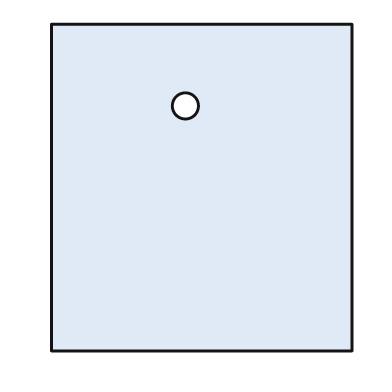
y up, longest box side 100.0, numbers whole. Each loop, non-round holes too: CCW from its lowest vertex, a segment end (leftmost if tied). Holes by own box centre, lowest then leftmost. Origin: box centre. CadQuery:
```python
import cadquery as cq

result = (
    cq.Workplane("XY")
    .moveTo(-46.0, -50.0)
    .lineTo(46.0, -50.0)
    .lineTo(46.0, 50.0)
    .lineTo(-46.0, 50.0)
    .close()
    .moveTo(-5.0, 25.0)
    .circle(4.0)
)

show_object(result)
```